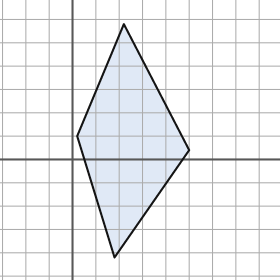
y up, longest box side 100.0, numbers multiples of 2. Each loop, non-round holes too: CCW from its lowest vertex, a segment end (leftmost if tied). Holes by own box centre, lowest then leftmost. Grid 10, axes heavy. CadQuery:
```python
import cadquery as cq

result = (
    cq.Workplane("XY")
    .moveTo(18.0, -42.0)
    .lineTo(50.0, 4.0)
    .lineTo(22.0, 58.0)
    .lineTo(2.0, 10.0)
    .close()
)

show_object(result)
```